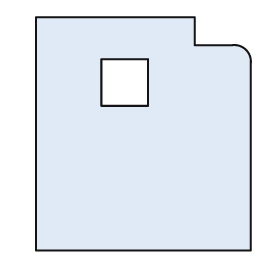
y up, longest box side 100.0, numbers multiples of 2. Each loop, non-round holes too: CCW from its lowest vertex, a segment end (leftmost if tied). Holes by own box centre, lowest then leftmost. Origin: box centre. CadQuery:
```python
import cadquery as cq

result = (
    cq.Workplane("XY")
    .moveTo(-46.0, -50.0)
    .lineTo(46.0, -50.0)
    .lineTo(46.0, 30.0)
    .threePointArc((44.0, 36.0), (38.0, 38.0))
    .lineTo(22.0, 38.0)
    .lineTo(22.0, 50.0)
    .lineTo(-46.0, 50.0)
    .close()
    .moveTo(-18.0, 12.0)
    .lineTo(2.0, 12.0)
    .lineTo(2.0, 32.0)
    .lineTo(-18.0, 32.0)
    .close()
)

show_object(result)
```